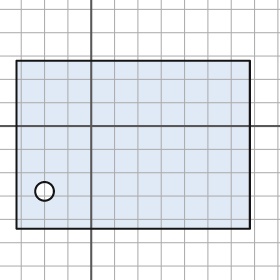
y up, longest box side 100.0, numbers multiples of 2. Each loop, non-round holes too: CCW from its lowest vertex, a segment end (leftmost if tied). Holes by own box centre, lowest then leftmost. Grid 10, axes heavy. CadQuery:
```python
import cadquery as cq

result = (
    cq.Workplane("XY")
    .moveTo(-32.0, -44.0)
    .lineTo(68.0, -44.0)
    .lineTo(68.0, 28.0)
    .lineTo(-32.0, 28.0)
    .close()
    .moveTo(-20.0, -28.0)
    .circle(4.0)
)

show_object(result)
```